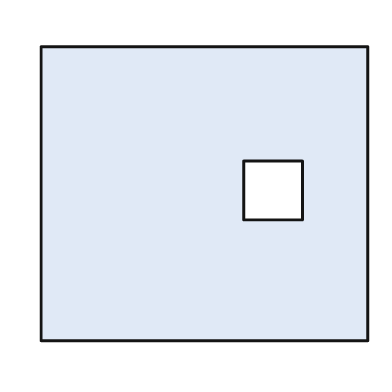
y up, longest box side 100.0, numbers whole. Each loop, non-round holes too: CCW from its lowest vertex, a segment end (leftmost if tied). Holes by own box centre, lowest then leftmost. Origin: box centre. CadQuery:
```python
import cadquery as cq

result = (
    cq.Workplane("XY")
    .moveTo(-50.0, -45.0)
    .lineTo(50.0, -45.0)
    .lineTo(50.0, 45.0)
    .lineTo(-50.0, 45.0)
    .close()
    .moveTo(12.0, -8.0)
    .lineTo(30.0, -8.0)
    .lineTo(30.0, 10.0)
    .lineTo(12.0, 10.0)
    .close()
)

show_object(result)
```